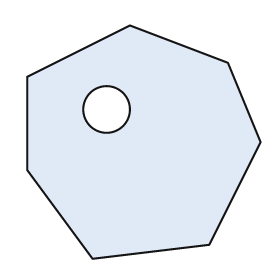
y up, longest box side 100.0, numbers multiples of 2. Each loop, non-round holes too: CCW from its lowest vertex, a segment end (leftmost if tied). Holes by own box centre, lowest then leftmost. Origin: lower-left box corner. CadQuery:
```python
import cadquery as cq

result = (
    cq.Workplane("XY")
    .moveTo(28.0, 0.0)
    .lineTo(78.0, 6.0)
    .lineTo(100.0, 50.0)
    .lineTo(86.0, 84.0)
    .lineTo(44.0, 100.0)
    .lineTo(0.0, 78.0)
    .lineTo(0.0, 38.0)
    .close()
    .moveTo(34.0, 64.0)
    .circle(10.0)
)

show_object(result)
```